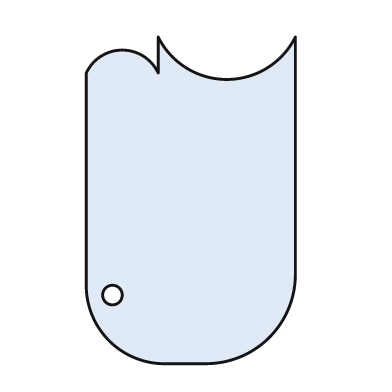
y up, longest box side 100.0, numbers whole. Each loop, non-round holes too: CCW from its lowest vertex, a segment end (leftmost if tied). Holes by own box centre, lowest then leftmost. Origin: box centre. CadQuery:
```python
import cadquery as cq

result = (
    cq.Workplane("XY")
    .moveTo(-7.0, -50.0)
    .lineTo(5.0, -50.0)
    .threePointArc((24.0, -42.0), (32.0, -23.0))
    .lineTo(32.0, 50.0)
    .threePointArc((11.0, 37.0), (-10.0, 50.0))
    .lineTo(-10.0, 39.0)
    .threePointArc((-21.0, 46.0), (-32.0, 39.0))
    .lineTo(-32.0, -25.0)
    .threePointArc((-25.0, -43.0), (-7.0, -50.0))
    .close()
    .moveTo(-24.0, -29.0)
    .circle(3.0)
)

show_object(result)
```